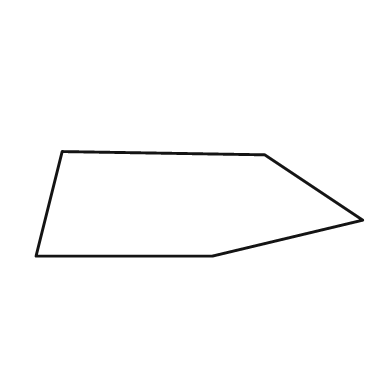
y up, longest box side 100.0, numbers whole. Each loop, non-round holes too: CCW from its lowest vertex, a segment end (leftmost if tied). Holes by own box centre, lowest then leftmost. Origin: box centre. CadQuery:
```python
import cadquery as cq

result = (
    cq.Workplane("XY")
    .moveTo(-50.0, -16.0)
    .lineTo(4.0, -16.0)
    .lineTo(50.0, -5.0)
    .lineTo(20.0, 15.0)
    .lineTo(-42.0, 16.0)
    .close()
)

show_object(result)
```